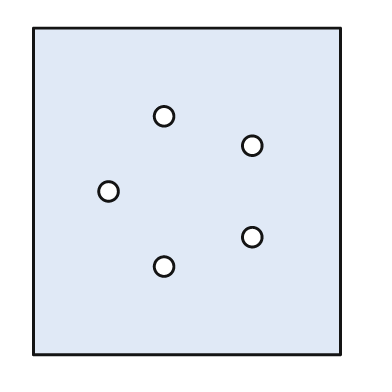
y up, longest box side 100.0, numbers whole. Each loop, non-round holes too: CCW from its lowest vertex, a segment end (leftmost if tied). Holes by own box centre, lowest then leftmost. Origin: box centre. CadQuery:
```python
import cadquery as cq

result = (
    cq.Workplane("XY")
    .moveTo(-47.0, -50.0)
    .lineTo(47.0, -50.0)
    .lineTo(47.0, 50.0)
    .lineTo(-47.0, 50.0)
    .close()
    .moveTo(-7.0, -23.0)
    .circle(3.0)
    .moveTo(20.0, -14.0)
    .circle(3.0)
    .moveTo(-24.0, 0.0)
    .circle(3.0)
    .moveTo(20.0, 14.0)
    .circle(3.0)
    .moveTo(-7.0, 23.0)
    .circle(3.0)
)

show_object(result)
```